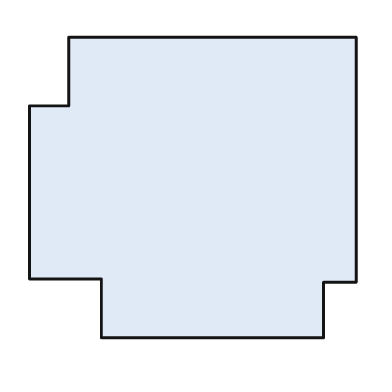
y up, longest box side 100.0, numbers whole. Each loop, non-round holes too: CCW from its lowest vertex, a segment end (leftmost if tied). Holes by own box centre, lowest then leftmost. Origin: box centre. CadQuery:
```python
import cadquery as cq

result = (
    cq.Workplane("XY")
    .moveTo(-28.0, -46.0)
    .lineTo(40.0, -46.0)
    .lineTo(40.0, -29.0)
    .lineTo(50.0, -29.0)
    .lineTo(50.0, 46.0)
    .lineTo(-38.0, 46.0)
    .lineTo(-38.0, 25.0)
    .lineTo(-50.0, 25.0)
    .lineTo(-50.0, -28.0)
    .lineTo(-28.0, -28.0)
    .close()
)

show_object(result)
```